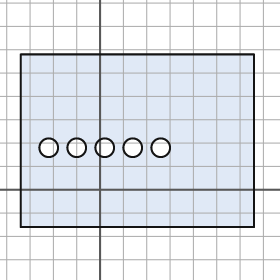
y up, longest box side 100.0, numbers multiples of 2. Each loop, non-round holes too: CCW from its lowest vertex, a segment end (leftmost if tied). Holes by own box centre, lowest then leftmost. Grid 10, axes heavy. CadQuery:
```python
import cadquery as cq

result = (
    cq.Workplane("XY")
    .moveTo(-34.0, -16.0)
    .lineTo(66.0, -16.0)
    .lineTo(66.0, 58.0)
    .lineTo(-34.0, 58.0)
    .close()
    .moveTo(-22.0, 18.0)
    .circle(4.0)
    .moveTo(-10.0, 18.0)
    .circle(4.0)
    .moveTo(2.0, 18.0)
    .circle(4.0)
    .moveTo(14.0, 18.0)
    .circle(4.0)
    .moveTo(26.0, 18.0)
    .circle(4.0)
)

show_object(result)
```